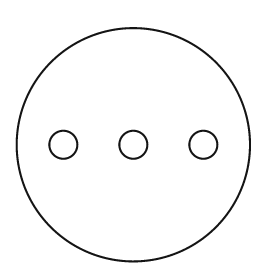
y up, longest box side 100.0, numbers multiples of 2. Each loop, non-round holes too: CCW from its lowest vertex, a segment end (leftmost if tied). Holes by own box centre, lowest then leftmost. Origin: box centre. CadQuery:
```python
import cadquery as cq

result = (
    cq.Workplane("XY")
    .moveTo(0.0, 0.0)
    .circle(50.0)
    .moveTo(-30.0, 0.0)
    .circle(6.0)
    .moveTo(0.0, 0.0)
    .circle(6.0)
    .moveTo(30.0, 0.0)
    .circle(6.0)
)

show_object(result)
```